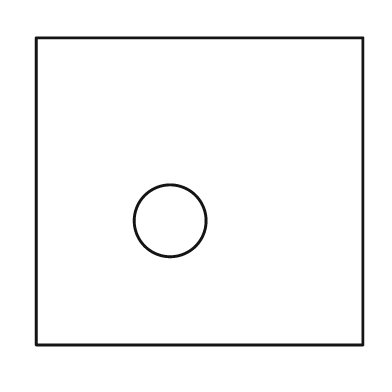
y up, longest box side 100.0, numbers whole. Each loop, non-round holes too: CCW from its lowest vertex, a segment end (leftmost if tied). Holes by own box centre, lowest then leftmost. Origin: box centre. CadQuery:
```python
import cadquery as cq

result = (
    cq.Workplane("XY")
    .moveTo(-50.0, -47.0)
    .lineTo(50.0, -47.0)
    .lineTo(50.0, 47.0)
    .lineTo(-50.0, 47.0)
    .close()
    .moveTo(-9.0, -9.0)
    .circle(11.0)
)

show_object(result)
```